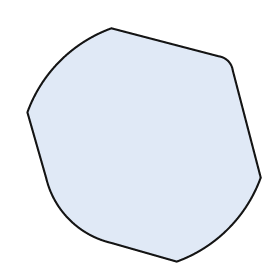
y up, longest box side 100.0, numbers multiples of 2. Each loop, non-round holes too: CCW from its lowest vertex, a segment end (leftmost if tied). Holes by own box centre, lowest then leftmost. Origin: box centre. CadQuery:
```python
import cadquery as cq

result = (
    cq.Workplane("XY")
    .moveTo(14.0, -50.0)
    .threePointArc((36.0, -36.0), (50.0, -14.0))
    .lineTo(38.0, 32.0)
    .threePointArc((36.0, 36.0), (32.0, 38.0))
    .lineTo(-14.0, 50.0)
    .threePointArc((-36.0, 36.0), (-50.0, 14.0))
    .lineTo(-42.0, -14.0)
    .threePointArc((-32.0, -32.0), (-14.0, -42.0))
    .close()
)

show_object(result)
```